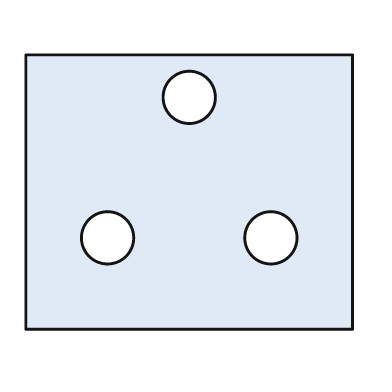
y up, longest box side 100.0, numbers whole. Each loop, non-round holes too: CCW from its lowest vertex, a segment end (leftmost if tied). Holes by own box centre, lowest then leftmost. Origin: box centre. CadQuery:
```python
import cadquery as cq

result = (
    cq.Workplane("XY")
    .moveTo(-50.0, -42.0)
    .lineTo(50.0, -42.0)
    .lineTo(50.0, 42.0)
    .lineTo(-50.0, 42.0)
    .close()
    .moveTo(-25.0, -14.0)
    .circle(8.0)
    .moveTo(25.0, -14.0)
    .circle(8.0)
    .moveTo(0.0, 29.0)
    .circle(8.0)
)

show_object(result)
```